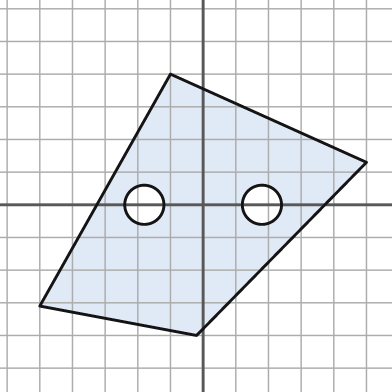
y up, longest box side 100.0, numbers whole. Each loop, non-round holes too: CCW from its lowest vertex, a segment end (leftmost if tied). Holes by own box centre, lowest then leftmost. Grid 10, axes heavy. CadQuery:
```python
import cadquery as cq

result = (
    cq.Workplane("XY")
    .moveTo(-2.0, -40.0)
    .lineTo(50.0, 13.0)
    .lineTo(-10.0, 40.0)
    .lineTo(-50.0, -31.0)
    .close()
    .moveTo(-18.0, 0.0)
    .circle(6.0)
    .moveTo(18.0, 0.0)
    .circle(6.0)
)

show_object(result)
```